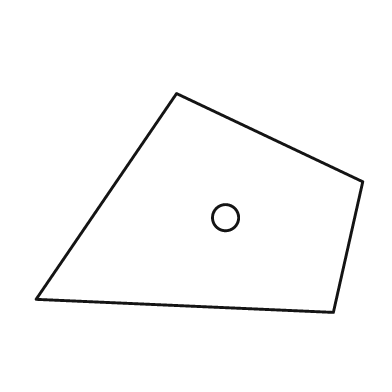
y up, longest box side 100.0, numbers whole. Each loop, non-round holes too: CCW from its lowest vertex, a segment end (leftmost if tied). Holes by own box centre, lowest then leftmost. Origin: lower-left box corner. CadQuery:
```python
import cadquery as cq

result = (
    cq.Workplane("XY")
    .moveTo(91.0, 0.0)
    .lineTo(100.0, 40.0)
    .lineTo(43.0, 67.0)
    .lineTo(0.0, 4.0)
    .close()
    .moveTo(58.0, 29.0)
    .circle(4.0)
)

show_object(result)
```